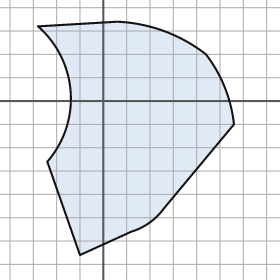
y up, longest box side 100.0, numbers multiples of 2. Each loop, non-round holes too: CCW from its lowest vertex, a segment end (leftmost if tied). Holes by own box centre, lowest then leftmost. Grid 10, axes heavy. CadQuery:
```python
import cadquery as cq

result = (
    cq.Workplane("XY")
    .moveTo(-10.0, -66.0)
    .lineTo(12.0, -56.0)
    .threePointArc((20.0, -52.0), (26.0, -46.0))
    .lineTo(56.0, -10.0)
    .threePointArc((52.0, 6.0), (44.0, 20.0))
    .threePointArc((26.0, 30.0), (6.0, 34.0))
    .lineTo(-28.0, 32.0)
    .threePointArc((-14.0, 4.0), (-24.0, -26.0))
    .close()
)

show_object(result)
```